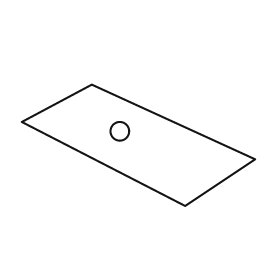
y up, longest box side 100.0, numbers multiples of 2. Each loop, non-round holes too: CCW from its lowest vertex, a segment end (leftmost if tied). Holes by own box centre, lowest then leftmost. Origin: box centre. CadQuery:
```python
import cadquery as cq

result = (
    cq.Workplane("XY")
    .moveTo(20.0, -26.0)
    .lineTo(50.0, -6.0)
    .lineTo(-20.0, 26.0)
    .lineTo(-50.0, 10.0)
    .close()
    .moveTo(-8.0, 6.0)
    .circle(4.0)
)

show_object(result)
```